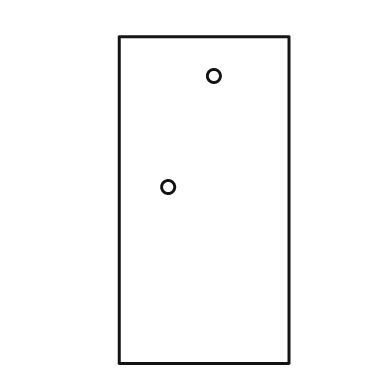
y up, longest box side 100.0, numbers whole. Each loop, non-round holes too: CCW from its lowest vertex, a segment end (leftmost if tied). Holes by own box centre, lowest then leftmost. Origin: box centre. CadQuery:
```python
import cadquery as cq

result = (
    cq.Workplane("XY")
    .moveTo(-26.0, -50.0)
    .lineTo(26.0, -50.0)
    .lineTo(26.0, 50.0)
    .lineTo(-26.0, 50.0)
    .close()
    .moveTo(-11.0, 4.0)
    .circle(2.0)
    .moveTo(3.0, 38.0)
    .circle(2.0)
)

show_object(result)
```